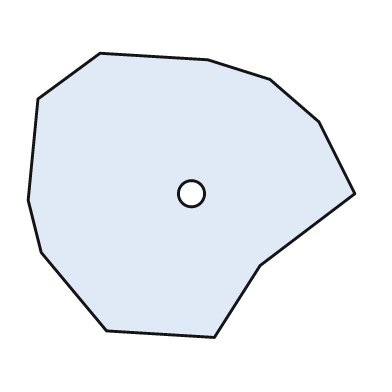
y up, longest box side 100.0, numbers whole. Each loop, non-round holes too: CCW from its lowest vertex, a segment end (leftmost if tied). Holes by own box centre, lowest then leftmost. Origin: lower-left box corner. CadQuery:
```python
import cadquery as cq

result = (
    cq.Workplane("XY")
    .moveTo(57.0, 0.0)
    .lineTo(71.0, 22.0)
    .lineTo(100.0, 44.0)
    .lineTo(89.0, 66.0)
    .lineTo(74.0, 79.0)
    .lineTo(55.0, 85.0)
    .lineTo(22.0, 87.0)
    .lineTo(3.0, 73.0)
    .lineTo(0.0, 42.0)
    .lineTo(4.0, 26.0)
    .lineTo(24.0, 2.0)
    .close()
    .moveTo(50.0, 44.0)
    .circle(4.0)
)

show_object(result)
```